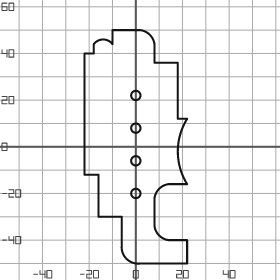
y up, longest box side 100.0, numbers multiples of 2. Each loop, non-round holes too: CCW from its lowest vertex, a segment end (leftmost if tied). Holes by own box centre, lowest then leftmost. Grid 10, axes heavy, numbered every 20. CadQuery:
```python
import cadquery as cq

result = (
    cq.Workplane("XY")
    .moveTo(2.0, -50.0)
    .lineTo(22.0, -50.0)
    .lineTo(22.0, -40.0)
    .lineTo(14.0, -40.0)
    .threePointArc((10.0, -38.0), (8.0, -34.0))
    .lineTo(8.0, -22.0)
    .threePointArc((10.0, -18.0), (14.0, -16.0))
    .lineTo(22.0, -16.0)
    .threePointArc((18.0, -2.0), (22.0, 12.0))
    .lineTo(18.0, 12.0)
    .lineTo(18.0, 36.0)
    .lineTo(8.0, 36.0)
    .lineTo(8.0, 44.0)
    .threePointArc((6.0, 48.0), (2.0, 50.0))
    .lineTo(-10.0, 50.0)
    .lineTo(-10.0, 44.0)
    .threePointArc((-14.0, 46.0), (-18.0, 44.0))
    .lineTo(-18.0, 40.0)
    .lineTo(-22.0, 40.0)
    .lineTo(-22.0, -12.0)
    .lineTo(-16.0, -12.0)
    .lineTo(-16.0, -30.0)
    .lineTo(-6.0, -30.0)
    .lineTo(-6.0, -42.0)
    .threePointArc((-4.0, -48.0), (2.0, -50.0))
    .close()
    .moveTo(0.0, -20.0)
    .circle(2.0)
    .moveTo(0.0, -6.0)
    .circle(2.0)
    .moveTo(0.0, 8.0)
    .circle(2.0)
    .moveTo(0.0, 22.0)
    .circle(2.0)
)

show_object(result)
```